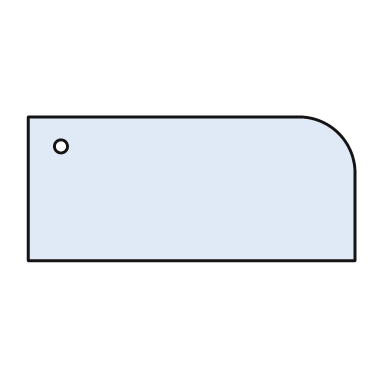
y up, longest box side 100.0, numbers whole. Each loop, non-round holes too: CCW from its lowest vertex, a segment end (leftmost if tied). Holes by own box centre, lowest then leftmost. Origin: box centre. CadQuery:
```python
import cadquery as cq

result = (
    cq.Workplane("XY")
    .moveTo(-50.0, -22.0)
    .lineTo(50.0, -22.0)
    .lineTo(50.0, 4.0)
    .threePointArc((45.0, 17.0), (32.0, 22.0))
    .lineTo(-50.0, 22.0)
    .close()
    .moveTo(-40.0, 13.0)
    .circle(2.0)
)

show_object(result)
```